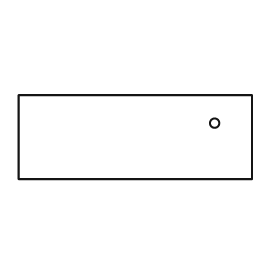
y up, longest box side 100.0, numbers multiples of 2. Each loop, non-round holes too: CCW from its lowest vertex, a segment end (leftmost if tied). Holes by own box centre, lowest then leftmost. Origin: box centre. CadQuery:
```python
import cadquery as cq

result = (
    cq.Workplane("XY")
    .moveTo(-50.0, -18.0)
    .lineTo(50.0, -18.0)
    .lineTo(50.0, 18.0)
    .lineTo(-50.0, 18.0)
    .close()
    .moveTo(34.0, 6.0)
    .circle(2.0)
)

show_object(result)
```